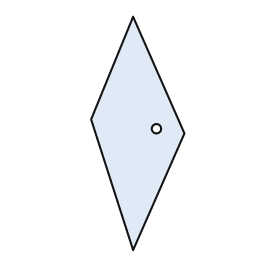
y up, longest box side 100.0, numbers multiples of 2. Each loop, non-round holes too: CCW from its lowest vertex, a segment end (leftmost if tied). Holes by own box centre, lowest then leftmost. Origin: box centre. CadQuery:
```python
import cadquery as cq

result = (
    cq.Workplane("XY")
    .moveTo(-2.0, -50.0)
    .lineTo(20.0, 0.0)
    .lineTo(-2.0, 50.0)
    .lineTo(-20.0, 6.0)
    .close()
    .moveTo(8.0, 2.0)
    .circle(2.0)
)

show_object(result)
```